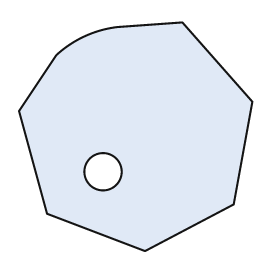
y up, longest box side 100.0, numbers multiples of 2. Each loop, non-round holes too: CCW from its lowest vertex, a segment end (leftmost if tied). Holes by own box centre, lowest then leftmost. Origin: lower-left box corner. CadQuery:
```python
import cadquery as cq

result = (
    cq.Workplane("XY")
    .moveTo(54.0, 0.0)
    .lineTo(92.0, 20.0)
    .lineTo(100.0, 64.0)
    .lineTo(70.0, 98.0)
    .lineTo(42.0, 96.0)
    .threePointArc((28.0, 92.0), (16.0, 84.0))
    .lineTo(0.0, 60.0)
    .lineTo(12.0, 16.0)
    .close()
    .moveTo(36.0, 34.0)
    .circle(8.0)
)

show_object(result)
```